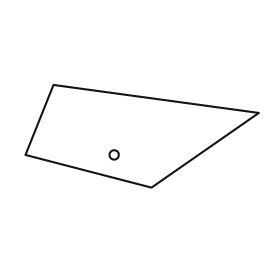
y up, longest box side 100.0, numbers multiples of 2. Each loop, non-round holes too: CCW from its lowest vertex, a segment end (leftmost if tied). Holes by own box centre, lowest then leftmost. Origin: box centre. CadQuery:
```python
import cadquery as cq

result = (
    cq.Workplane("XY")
    .moveTo(4.0, -22.0)
    .lineTo(50.0, 10.0)
    .lineTo(-38.0, 22.0)
    .lineTo(-50.0, -8.0)
    .close()
    .moveTo(-12.0, -8.0)
    .circle(2.0)
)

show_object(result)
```